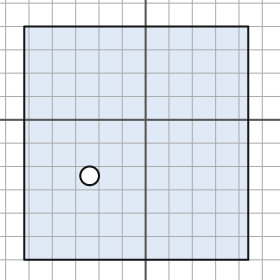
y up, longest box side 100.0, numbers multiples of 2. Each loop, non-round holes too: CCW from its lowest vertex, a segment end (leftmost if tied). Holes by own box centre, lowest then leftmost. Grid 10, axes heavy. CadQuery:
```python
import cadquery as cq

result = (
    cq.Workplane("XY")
    .moveTo(-52.0, -60.0)
    .lineTo(44.0, -60.0)
    .lineTo(44.0, 40.0)
    .lineTo(-52.0, 40.0)
    .close()
    .moveTo(-24.0, -24.0)
    .circle(4.0)
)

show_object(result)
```